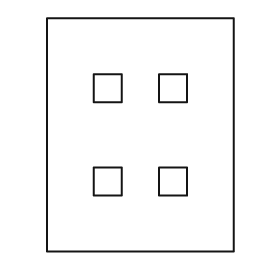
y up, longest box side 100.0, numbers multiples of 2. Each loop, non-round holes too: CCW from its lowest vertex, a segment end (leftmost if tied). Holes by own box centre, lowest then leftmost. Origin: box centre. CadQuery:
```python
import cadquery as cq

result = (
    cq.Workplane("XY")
    .moveTo(-40.0, -50.0)
    .lineTo(40.0, -50.0)
    .lineTo(40.0, 50.0)
    .lineTo(-40.0, 50.0)
    .close()
    .moveTo(-20.0, -26.0)
    .lineTo(-8.0, -26.0)
    .lineTo(-8.0, -14.0)
    .lineTo(-20.0, -14.0)
    .close()
    .moveTo(8.0, -26.0)
    .lineTo(20.0, -26.0)
    .lineTo(20.0, -14.0)
    .lineTo(8.0, -14.0)
    .close()
    .moveTo(-20.0, 14.0)
    .lineTo(-8.0, 14.0)
    .lineTo(-8.0, 26.0)
    .lineTo(-20.0, 26.0)
    .close()
    .moveTo(8.0, 14.0)
    .lineTo(20.0, 14.0)
    .lineTo(20.0, 26.0)
    .lineTo(8.0, 26.0)
    .close()
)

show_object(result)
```